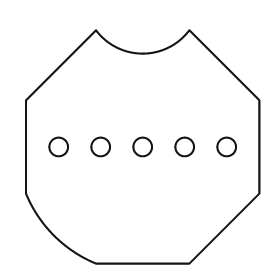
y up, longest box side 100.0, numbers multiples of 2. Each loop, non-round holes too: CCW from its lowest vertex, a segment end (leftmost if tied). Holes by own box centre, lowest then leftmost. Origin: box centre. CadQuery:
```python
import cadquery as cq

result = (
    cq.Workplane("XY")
    .moveTo(-20.0, -50.0)
    .lineTo(20.0, -50.0)
    .lineTo(50.0, -20.0)
    .lineTo(50.0, 20.0)
    .lineTo(20.0, 50.0)
    .threePointArc((0.0, 40.0), (-20.0, 50.0))
    .lineTo(-50.0, 20.0)
    .lineTo(-50.0, -20.0)
    .threePointArc((-38.0, -38.0), (-20.0, -50.0))
    .close()
    .moveTo(-36.0, 0.0)
    .circle(4.0)
    .moveTo(-18.0, 0.0)
    .circle(4.0)
    .moveTo(0.0, 0.0)
    .circle(4.0)
    .moveTo(18.0, 0.0)
    .circle(4.0)
    .moveTo(36.0, 0.0)
    .circle(4.0)
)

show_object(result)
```